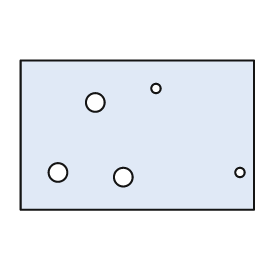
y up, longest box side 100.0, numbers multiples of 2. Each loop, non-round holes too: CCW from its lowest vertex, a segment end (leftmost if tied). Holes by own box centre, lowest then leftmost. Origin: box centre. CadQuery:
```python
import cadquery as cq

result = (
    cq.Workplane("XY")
    .moveTo(-50.0, -32.0)
    .lineTo(50.0, -32.0)
    .lineTo(50.0, 32.0)
    .lineTo(-50.0, 32.0)
    .close()
    .moveTo(-6.0, -18.0)
    .circle(4.0)
    .moveTo(-34.0, -16.0)
    .circle(4.0)
    .moveTo(44.0, -16.0)
    .circle(2.0)
    .moveTo(-18.0, 14.0)
    .circle(4.0)
    .moveTo(8.0, 20.0)
    .circle(2.0)
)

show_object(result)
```